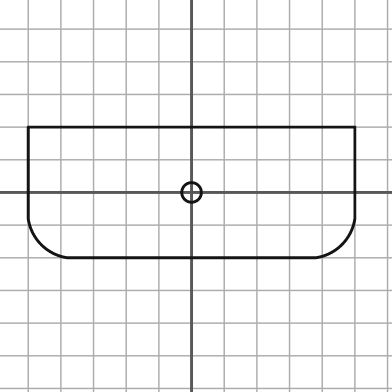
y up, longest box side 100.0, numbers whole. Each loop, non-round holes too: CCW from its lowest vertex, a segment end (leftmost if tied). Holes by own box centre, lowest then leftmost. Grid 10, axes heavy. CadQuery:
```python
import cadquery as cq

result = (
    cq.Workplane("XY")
    .moveTo(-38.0, -20.0)
    .lineTo(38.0, -20.0)
    .threePointArc((46.0, -16.0), (50.0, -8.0))
    .lineTo(50.0, 20.0)
    .lineTo(-50.0, 20.0)
    .lineTo(-50.0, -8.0)
    .threePointArc((-46.0, -16.0), (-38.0, -20.0))
    .close()
    .moveTo(0.0, 0.0)
    .circle(3.0)
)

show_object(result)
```